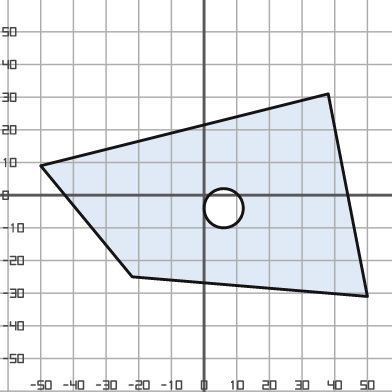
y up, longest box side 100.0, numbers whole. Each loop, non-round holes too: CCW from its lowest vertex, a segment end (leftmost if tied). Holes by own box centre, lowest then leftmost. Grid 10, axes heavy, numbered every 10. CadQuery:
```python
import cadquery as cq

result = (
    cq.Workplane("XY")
    .moveTo(50.0, -31.0)
    .lineTo(38.0, 31.0)
    .lineTo(-50.0, 9.0)
    .lineTo(-22.0, -25.0)
    .close()
    .moveTo(6.0, -4.0)
    .circle(6.0)
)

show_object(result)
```